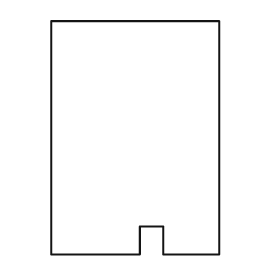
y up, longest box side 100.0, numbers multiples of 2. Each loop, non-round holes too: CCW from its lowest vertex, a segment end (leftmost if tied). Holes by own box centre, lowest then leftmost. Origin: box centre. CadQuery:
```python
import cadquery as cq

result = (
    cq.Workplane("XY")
    .moveTo(-36.0, -50.0)
    .lineTo(2.0, -50.0)
    .lineTo(2.0, -38.0)
    .lineTo(12.0, -38.0)
    .lineTo(12.0, -50.0)
    .lineTo(36.0, -50.0)
    .lineTo(36.0, 50.0)
    .lineTo(-36.0, 50.0)
    .close()
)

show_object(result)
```